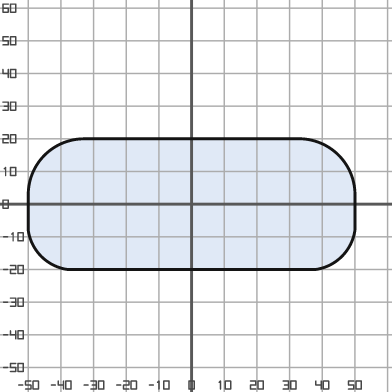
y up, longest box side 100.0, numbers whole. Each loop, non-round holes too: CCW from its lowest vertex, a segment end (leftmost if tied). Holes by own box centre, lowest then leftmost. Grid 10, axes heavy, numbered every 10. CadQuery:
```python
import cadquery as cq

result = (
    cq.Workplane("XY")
    .moveTo(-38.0, -20.0)
    .lineTo(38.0, -20.0)
    .threePointArc((46.0, -16.0), (50.0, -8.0))
    .lineTo(50.0, 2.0)
    .threePointArc((45.0, 15.0), (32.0, 20.0))
    .lineTo(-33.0, 20.0)
    .threePointArc((-45.0, 15.0), (-50.0, 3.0))
    .lineTo(-50.0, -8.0)
    .threePointArc((-46.0, -16.0), (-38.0, -20.0))
    .close()
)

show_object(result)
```